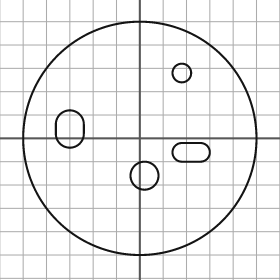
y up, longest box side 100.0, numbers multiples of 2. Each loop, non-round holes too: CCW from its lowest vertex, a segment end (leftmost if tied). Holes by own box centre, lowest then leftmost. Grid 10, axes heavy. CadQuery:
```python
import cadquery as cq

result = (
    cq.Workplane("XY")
    .moveTo(0.0, 0.0)
    .circle(50.0)
    .moveTo(2.0, -16.0)
    .circle(6.0)
    .moveTo(18.0, -10.0)
    .lineTo(26.0, -10.0)
    .threePointArc((30.0, -6.0), (26.0, -2.0))
    .lineTo(18.0, -2.0)
    .threePointArc((14.0, -6.0), (18.0, -10.0))
    .close()
    .moveTo(-36.0, 2.0)
    .threePointArc((-30.0, -4.0), (-24.0, 2.0))
    .lineTo(-24.0, 6.0)
    .threePointArc((-30.0, 12.0), (-36.0, 6.0))
    .close()
    .moveTo(18.0, 28.0)
    .circle(4.0)
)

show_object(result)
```